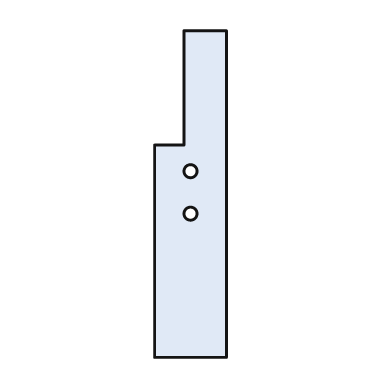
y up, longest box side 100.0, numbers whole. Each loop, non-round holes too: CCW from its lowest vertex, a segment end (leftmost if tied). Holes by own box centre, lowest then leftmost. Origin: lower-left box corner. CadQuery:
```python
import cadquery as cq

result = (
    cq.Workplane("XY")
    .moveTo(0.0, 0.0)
    .lineTo(22.0, 0.0)
    .lineTo(22.0, 100.0)
    .lineTo(9.0, 100.0)
    .lineTo(9.0, 65.0)
    .lineTo(0.0, 65.0)
    .close()
    .moveTo(11.0, 44.0)
    .circle(2.0)
    .moveTo(11.0, 57.0)
    .circle(2.0)
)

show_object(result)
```